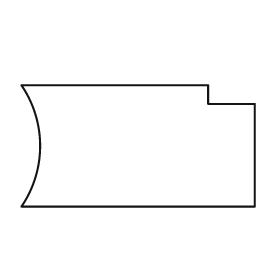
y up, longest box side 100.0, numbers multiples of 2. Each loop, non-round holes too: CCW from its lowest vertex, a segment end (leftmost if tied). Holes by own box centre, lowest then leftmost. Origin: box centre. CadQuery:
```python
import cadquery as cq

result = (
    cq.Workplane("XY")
    .moveTo(-50.0, -26.0)
    .lineTo(50.0, -26.0)
    .lineTo(50.0, 18.0)
    .lineTo(30.0, 18.0)
    .lineTo(30.0, 26.0)
    .lineTo(-50.0, 26.0)
    .threePointArc((-42.0, 0.0), (-50.0, -26.0))
    .close()
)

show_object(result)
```